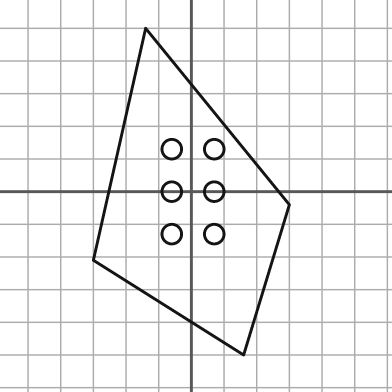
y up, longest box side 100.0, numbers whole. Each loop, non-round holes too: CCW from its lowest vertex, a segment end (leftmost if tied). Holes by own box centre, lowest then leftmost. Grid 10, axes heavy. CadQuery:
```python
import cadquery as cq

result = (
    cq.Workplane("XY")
    .moveTo(16.0, -50.0)
    .lineTo(30.0, -4.0)
    .lineTo(-14.0, 50.0)
    .lineTo(-30.0, -21.0)
    .close()
    .moveTo(-6.0, -13.0)
    .circle(3.0)
    .moveTo(7.0, -13.0)
    .circle(3.0)
    .moveTo(-6.0, 0.0)
    .circle(3.0)
    .moveTo(7.0, 0.0)
    .circle(3.0)
    .moveTo(-6.0, 13.0)
    .circle(3.0)
    .moveTo(7.0, 13.0)
    .circle(3.0)
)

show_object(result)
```